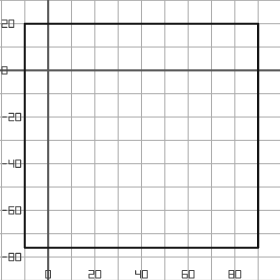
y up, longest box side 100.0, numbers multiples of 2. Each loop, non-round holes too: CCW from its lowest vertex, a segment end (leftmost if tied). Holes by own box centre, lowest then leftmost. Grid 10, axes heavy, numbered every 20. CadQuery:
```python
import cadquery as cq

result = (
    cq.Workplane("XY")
    .moveTo(-10.0, -76.0)
    .lineTo(90.0, -76.0)
    .lineTo(90.0, 20.0)
    .lineTo(-10.0, 20.0)
    .close()
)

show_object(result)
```